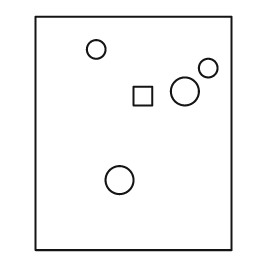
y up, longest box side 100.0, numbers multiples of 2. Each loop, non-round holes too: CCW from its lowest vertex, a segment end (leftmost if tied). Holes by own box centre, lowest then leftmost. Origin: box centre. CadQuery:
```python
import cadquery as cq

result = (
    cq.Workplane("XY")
    .moveTo(-42.0, -50.0)
    .lineTo(42.0, -50.0)
    .lineTo(42.0, 50.0)
    .lineTo(-42.0, 50.0)
    .close()
    .moveTo(-6.0, -20.0)
    .circle(6.0)
    .moveTo(0.0, 12.0)
    .lineTo(8.0, 12.0)
    .lineTo(8.0, 20.0)
    .lineTo(0.0, 20.0)
    .close()
    .moveTo(22.0, 18.0)
    .circle(6.0)
    .moveTo(32.0, 28.0)
    .circle(4.0)
    .moveTo(-16.0, 36.0)
    .circle(4.0)
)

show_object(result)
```